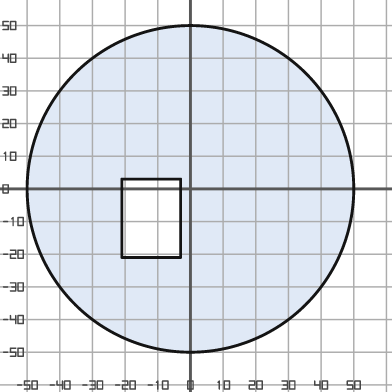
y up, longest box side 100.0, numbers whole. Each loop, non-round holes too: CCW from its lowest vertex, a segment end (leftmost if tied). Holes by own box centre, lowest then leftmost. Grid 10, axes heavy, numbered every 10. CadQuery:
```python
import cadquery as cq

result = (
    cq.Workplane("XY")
    .moveTo(0.0, 0.0)
    .circle(50.0)
    .moveTo(-21.0, -21.0)
    .lineTo(-3.0, -21.0)
    .lineTo(-3.0, 3.0)
    .lineTo(-21.0, 3.0)
    .close()
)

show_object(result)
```